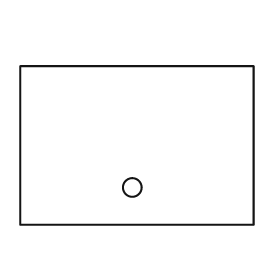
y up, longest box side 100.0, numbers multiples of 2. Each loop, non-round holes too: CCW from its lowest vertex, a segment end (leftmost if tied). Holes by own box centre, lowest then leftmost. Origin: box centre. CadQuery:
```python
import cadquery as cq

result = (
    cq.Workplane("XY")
    .moveTo(-50.0, -34.0)
    .lineTo(50.0, -34.0)
    .lineTo(50.0, 34.0)
    .lineTo(-50.0, 34.0)
    .close()
    .moveTo(-2.0, -18.0)
    .circle(4.0)
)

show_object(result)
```